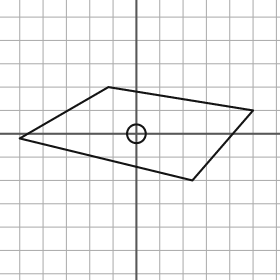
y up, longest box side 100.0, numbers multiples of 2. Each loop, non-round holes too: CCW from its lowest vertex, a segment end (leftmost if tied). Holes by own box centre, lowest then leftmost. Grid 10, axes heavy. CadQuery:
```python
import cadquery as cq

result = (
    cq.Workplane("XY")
    .moveTo(24.0, -20.0)
    .lineTo(50.0, 10.0)
    .lineTo(-12.0, 20.0)
    .lineTo(-50.0, -2.0)
    .close()
    .moveTo(0.0, 0.0)
    .circle(4.0)
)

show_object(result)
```